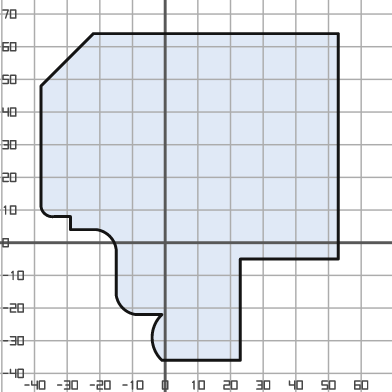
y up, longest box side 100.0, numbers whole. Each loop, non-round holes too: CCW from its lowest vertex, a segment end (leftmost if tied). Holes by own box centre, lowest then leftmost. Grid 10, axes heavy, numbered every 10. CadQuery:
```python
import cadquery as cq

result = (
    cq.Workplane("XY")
    .moveTo(-1.0, -36.0)
    .lineTo(23.0, -36.0)
    .lineTo(23.0, -5.0)
    .lineTo(53.0, -5.0)
    .lineTo(53.0, 64.0)
    .lineTo(-22.0, 64.0)
    .lineTo(-38.0, 48.0)
    .lineTo(-38.0, 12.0)
    .threePointArc((-37.0, 9.0), (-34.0, 8.0))
    .lineTo(-29.0, 8.0)
    .lineTo(-29.0, 4.0)
    .lineTo(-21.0, 4.0)
    .threePointArc((-17.0, 2.0), (-15.0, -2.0))
    .lineTo(-15.0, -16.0)
    .threePointArc((-13.0, -20.0), (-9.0, -22.0))
    .lineTo(-1.0, -22.0)
    .threePointArc((-4.0, -29.0), (-1.0, -36.0))
    .close()
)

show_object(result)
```